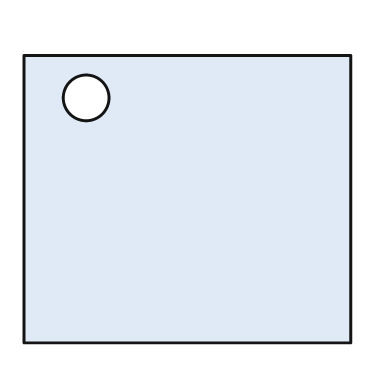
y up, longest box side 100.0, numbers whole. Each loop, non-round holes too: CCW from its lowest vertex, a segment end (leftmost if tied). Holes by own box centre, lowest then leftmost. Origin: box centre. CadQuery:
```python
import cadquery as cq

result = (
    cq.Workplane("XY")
    .moveTo(-50.0, -44.0)
    .lineTo(50.0, -44.0)
    .lineTo(50.0, 44.0)
    .lineTo(-50.0, 44.0)
    .close()
    .moveTo(-31.0, 31.0)
    .circle(7.0)
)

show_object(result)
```